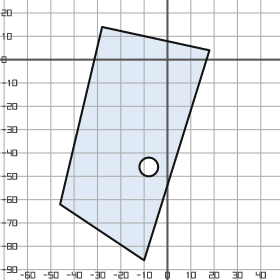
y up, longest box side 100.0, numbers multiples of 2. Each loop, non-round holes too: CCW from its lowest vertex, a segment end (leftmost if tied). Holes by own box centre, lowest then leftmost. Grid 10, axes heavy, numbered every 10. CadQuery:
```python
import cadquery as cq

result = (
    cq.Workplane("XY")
    .moveTo(-10.0, -86.0)
    .lineTo(18.0, 4.0)
    .lineTo(-28.0, 14.0)
    .lineTo(-46.0, -62.0)
    .close()
    .moveTo(-8.0, -46.0)
    .circle(4.0)
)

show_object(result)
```